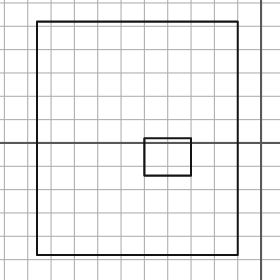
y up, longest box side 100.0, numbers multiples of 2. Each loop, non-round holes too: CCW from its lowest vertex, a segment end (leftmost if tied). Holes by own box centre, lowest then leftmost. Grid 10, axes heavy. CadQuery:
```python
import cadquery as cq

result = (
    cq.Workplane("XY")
    .moveTo(-96.0, -48.0)
    .lineTo(-10.0, -48.0)
    .lineTo(-10.0, 52.0)
    .lineTo(-96.0, 52.0)
    .close()
    .moveTo(-50.0, -14.0)
    .lineTo(-30.0, -14.0)
    .lineTo(-30.0, 2.0)
    .lineTo(-50.0, 2.0)
    .close()
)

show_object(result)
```